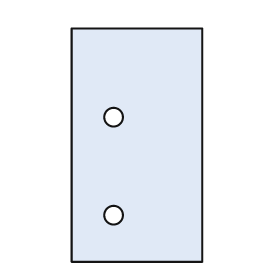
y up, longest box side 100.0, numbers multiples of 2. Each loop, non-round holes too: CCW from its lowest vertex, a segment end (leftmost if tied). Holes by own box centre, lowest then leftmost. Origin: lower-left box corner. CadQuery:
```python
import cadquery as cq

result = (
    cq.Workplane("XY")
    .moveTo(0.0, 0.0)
    .lineTo(56.0, 0.0)
    .lineTo(56.0, 100.0)
    .lineTo(0.0, 100.0)
    .close()
    .moveTo(18.0, 20.0)
    .circle(4.0)
    .moveTo(18.0, 62.0)
    .circle(4.0)
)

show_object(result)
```